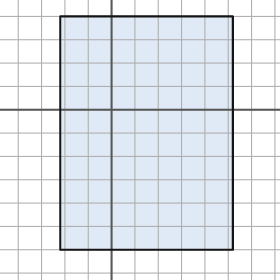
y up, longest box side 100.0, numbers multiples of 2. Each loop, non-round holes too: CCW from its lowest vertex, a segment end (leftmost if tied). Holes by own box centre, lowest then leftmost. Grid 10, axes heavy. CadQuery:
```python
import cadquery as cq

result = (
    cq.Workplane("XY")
    .moveTo(-22.0, -60.0)
    .lineTo(52.0, -60.0)
    .lineTo(52.0, 40.0)
    .lineTo(-22.0, 40.0)
    .close()
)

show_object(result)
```